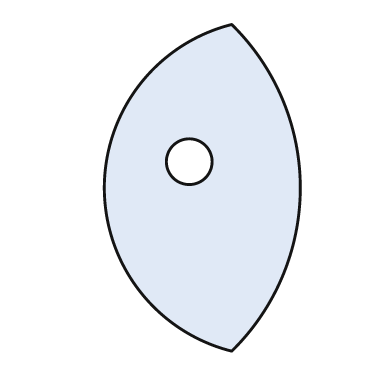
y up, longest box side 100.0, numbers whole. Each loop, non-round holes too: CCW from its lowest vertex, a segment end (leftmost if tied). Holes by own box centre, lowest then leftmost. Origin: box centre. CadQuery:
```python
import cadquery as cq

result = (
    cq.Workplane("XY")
    .moveTo(9.0, -50.0)
    .threePointArc((30.0, 0.0), (9.0, 50.0))
    .threePointArc((-30.0, 0.0), (9.0, -50.0))
    .close()
    .moveTo(-4.0, 8.0)
    .circle(7.0)
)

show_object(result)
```